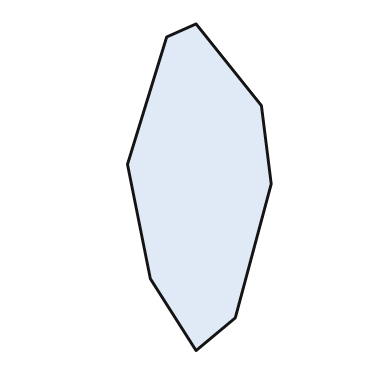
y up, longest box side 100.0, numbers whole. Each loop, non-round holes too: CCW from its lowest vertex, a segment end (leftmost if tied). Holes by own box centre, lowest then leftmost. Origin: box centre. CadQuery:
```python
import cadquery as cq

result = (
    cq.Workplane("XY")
    .moveTo(-1.0, -50.0)
    .lineTo(11.0, -40.0)
    .lineTo(22.0, 1.0)
    .lineTo(19.0, 25.0)
    .lineTo(-1.0, 50.0)
    .lineTo(-10.0, 46.0)
    .lineTo(-22.0, 7.0)
    .lineTo(-15.0, -28.0)
    .close()
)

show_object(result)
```